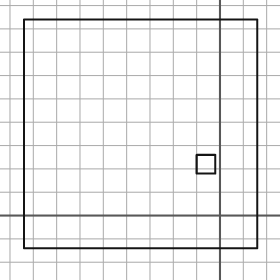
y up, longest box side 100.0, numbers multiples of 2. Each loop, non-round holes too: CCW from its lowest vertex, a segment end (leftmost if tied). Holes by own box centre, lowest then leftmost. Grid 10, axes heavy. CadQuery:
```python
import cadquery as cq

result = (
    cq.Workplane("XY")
    .moveTo(-84.0, -14.0)
    .lineTo(16.0, -14.0)
    .lineTo(16.0, 84.0)
    .lineTo(-84.0, 84.0)
    .close()
    .moveTo(-10.0, 18.0)
    .lineTo(-2.0, 18.0)
    .lineTo(-2.0, 26.0)
    .lineTo(-10.0, 26.0)
    .close()
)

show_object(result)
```